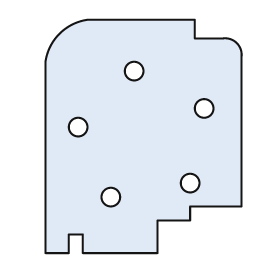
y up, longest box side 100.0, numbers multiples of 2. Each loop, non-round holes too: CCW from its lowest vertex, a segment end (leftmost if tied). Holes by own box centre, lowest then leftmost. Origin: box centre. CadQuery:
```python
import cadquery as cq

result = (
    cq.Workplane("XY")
    .moveTo(-42.0, -50.0)
    .lineTo(-32.0, -50.0)
    .lineTo(-32.0, -42.0)
    .lineTo(-26.0, -42.0)
    .lineTo(-26.0, -50.0)
    .lineTo(6.0, -50.0)
    .lineTo(6.0, -36.0)
    .lineTo(20.0, -36.0)
    .lineTo(20.0, -30.0)
    .lineTo(42.0, -30.0)
    .lineTo(42.0, 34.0)
    .threePointArc((40.0, 40.0), (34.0, 42.0))
    .lineTo(22.0, 42.0)
    .lineTo(22.0, 50.0)
    .lineTo(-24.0, 50.0)
    .threePointArc((-36.0, 44.0), (-42.0, 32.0))
    .close()
    .moveTo(-14.0, -26.0)
    .circle(4.0)
    .moveTo(20.0, -20.0)
    .circle(4.0)
    .moveTo(-28.0, 4.0)
    .circle(4.0)
    .moveTo(26.0, 12.0)
    .circle(4.0)
    .moveTo(-4.0, 28.0)
    .circle(4.0)
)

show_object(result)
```